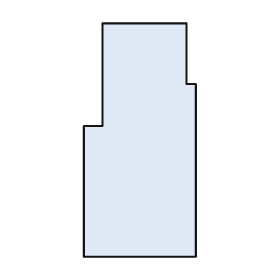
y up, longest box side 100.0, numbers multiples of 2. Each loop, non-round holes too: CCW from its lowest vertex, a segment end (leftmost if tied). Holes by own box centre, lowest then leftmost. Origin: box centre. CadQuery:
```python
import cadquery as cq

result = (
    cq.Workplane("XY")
    .moveTo(-24.0, -50.0)
    .lineTo(24.0, -50.0)
    .lineTo(24.0, 24.0)
    .lineTo(20.0, 24.0)
    .lineTo(20.0, 50.0)
    .lineTo(-16.0, 50.0)
    .lineTo(-16.0, 6.0)
    .lineTo(-24.0, 6.0)
    .close()
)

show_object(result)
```